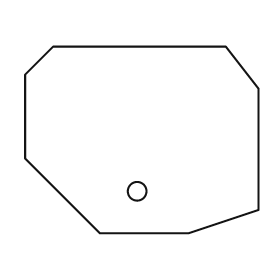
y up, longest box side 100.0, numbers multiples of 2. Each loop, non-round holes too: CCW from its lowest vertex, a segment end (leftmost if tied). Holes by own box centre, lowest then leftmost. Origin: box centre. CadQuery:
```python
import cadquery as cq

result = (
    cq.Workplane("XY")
    .moveTo(-18.0, -40.0)
    .lineTo(20.0, -40.0)
    .lineTo(50.0, -30.0)
    .lineTo(50.0, 22.0)
    .lineTo(36.0, 40.0)
    .lineTo(-38.0, 40.0)
    .lineTo(-50.0, 28.0)
    .lineTo(-50.0, -8.0)
    .close()
    .moveTo(-2.0, -22.0)
    .circle(4.0)
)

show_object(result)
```